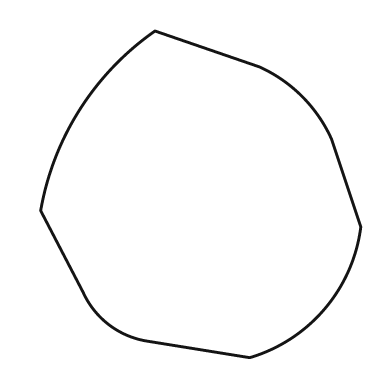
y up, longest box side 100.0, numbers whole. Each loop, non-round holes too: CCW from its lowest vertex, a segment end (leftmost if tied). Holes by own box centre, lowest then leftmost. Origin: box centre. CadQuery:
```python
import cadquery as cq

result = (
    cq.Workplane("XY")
    .moveTo(15.0, -50.0)
    .threePointArc((38.0, -35.0), (49.0, -10.0))
    .lineTo(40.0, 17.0)
    .threePointArc((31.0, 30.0), (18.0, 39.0))
    .lineTo(-14.0, 50.0)
    .threePointArc((-37.0, 26.0), (-49.0, -5.0))
    .lineTo(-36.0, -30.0)
    .threePointArc((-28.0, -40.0), (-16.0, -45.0))
    .close()
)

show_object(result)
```